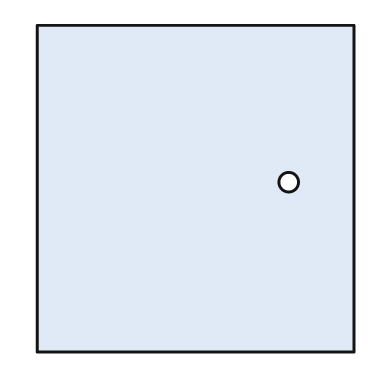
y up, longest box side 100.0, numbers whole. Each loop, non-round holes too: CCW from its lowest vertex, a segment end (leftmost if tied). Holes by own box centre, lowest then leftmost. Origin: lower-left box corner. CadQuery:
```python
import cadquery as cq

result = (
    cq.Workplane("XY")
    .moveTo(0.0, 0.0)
    .lineTo(97.0, 0.0)
    .lineTo(97.0, 100.0)
    .lineTo(0.0, 100.0)
    .close()
    .moveTo(77.0, 52.0)
    .circle(3.0)
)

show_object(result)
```